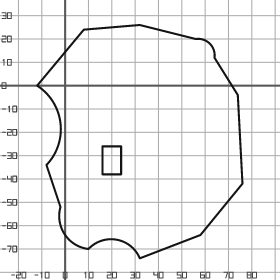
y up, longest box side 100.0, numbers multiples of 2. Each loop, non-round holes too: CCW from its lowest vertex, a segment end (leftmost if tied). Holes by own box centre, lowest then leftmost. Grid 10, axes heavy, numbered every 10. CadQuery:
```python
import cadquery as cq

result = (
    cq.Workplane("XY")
    .moveTo(32.0, -74.0)
    .lineTo(58.0, -64.0)
    .lineTo(76.0, -42.0)
    .lineTo(74.0, -4.0)
    .lineTo(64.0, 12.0)
    .threePointArc((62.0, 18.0), (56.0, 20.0))
    .lineTo(32.0, 26.0)
    .lineTo(8.0, 24.0)
    .lineTo(-12.0, 0.0)
    .threePointArc((-2.0, -16.0), (-8.0, -34.0))
    .lineTo(-2.0, -52.0)
    .threePointArc((0.0, -64.0), (10.0, -70.0))
    .threePointArc((22.0, -66.0), (32.0, -74.0))
    .close()
    .moveTo(16.0, -38.0)
    .lineTo(24.0, -38.0)
    .lineTo(24.0, -26.0)
    .lineTo(16.0, -26.0)
    .close()
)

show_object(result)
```